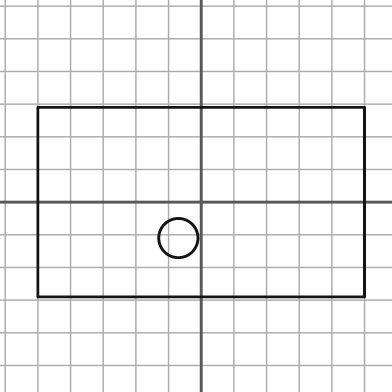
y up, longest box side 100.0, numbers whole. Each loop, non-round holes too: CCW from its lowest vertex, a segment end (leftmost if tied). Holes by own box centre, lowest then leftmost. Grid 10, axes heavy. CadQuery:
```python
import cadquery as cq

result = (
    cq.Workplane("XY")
    .moveTo(-50.0, -29.0)
    .lineTo(50.0, -29.0)
    .lineTo(50.0, 29.0)
    .lineTo(-50.0, 29.0)
    .close()
    .moveTo(-7.0, -11.0)
    .circle(6.0)
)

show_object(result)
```